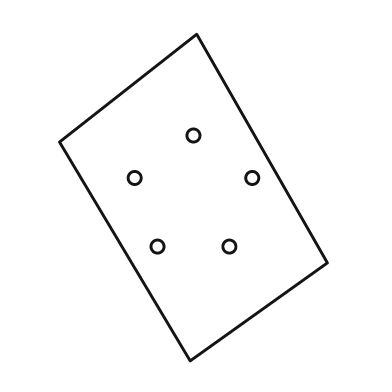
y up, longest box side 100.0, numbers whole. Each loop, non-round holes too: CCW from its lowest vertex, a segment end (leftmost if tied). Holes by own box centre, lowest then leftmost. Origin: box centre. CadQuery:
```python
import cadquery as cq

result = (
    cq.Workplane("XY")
    .moveTo(-1.0, -50.0)
    .lineTo(41.0, -20.0)
    .lineTo(1.0, 50.0)
    .lineTo(-41.0, 17.0)
    .close()
    .moveTo(-11.0, -15.0)
    .circle(2.0)
    .moveTo(11.0, -15.0)
    .circle(2.0)
    .moveTo(-18.0, 6.0)
    .circle(2.0)
    .moveTo(18.0, 6.0)
    .circle(2.0)
    .moveTo(0.0, 19.0)
    .circle(2.0)
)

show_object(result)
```